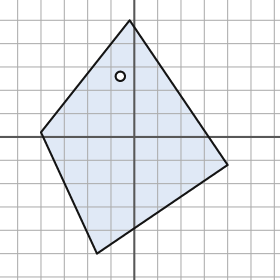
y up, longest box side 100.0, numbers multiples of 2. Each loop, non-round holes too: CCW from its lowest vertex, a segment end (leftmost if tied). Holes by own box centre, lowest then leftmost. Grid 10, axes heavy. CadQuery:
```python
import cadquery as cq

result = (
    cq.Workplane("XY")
    .moveTo(-16.0, -50.0)
    .lineTo(40.0, -12.0)
    .lineTo(-2.0, 50.0)
    .lineTo(-40.0, 2.0)
    .close()
    .moveTo(-6.0, 26.0)
    .circle(2.0)
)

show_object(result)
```